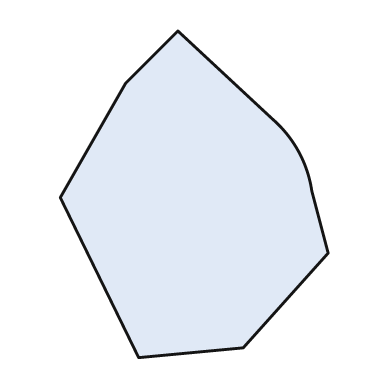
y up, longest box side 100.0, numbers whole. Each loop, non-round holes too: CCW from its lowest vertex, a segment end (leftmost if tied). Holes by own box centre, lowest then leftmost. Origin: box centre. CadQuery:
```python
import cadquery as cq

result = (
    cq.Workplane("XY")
    .moveTo(-17.0, -50.0)
    .lineTo(15.0, -47.0)
    .lineTo(41.0, -18.0)
    .lineTo(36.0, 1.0)
    .threePointArc((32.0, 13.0), (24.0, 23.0))
    .lineTo(-5.0, 50.0)
    .lineTo(-21.0, 34.0)
    .lineTo(-41.0, -1.0)
    .close()
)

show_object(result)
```